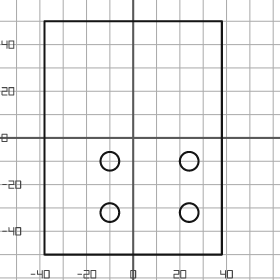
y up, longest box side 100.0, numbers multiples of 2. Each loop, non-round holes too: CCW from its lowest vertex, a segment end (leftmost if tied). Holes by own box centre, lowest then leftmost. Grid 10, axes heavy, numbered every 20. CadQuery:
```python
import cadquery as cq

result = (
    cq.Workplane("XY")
    .moveTo(-38.0, -50.0)
    .lineTo(38.0, -50.0)
    .lineTo(38.0, 50.0)
    .lineTo(-38.0, 50.0)
    .close()
    .moveTo(-10.0, -32.0)
    .circle(4.0)
    .moveTo(24.0, -32.0)
    .circle(4.0)
    .moveTo(-10.0, -10.0)
    .circle(4.0)
    .moveTo(24.0, -10.0)
    .circle(4.0)
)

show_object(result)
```